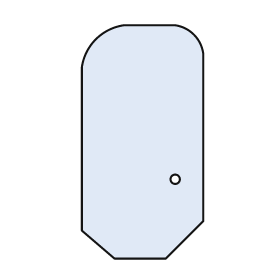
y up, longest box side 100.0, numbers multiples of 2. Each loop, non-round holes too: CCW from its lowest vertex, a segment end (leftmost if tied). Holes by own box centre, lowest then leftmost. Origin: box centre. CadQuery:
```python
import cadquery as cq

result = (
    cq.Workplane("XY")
    .moveTo(-12.0, -50.0)
    .lineTo(10.0, -50.0)
    .lineTo(26.0, -34.0)
    .lineTo(26.0, 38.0)
    .threePointArc((22.0, 46.0), (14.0, 50.0))
    .lineTo(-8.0, 50.0)
    .threePointArc((-20.0, 44.0), (-26.0, 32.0))
    .lineTo(-26.0, -38.0)
    .close()
    .moveTo(14.0, -16.0)
    .circle(2.0)
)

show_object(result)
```